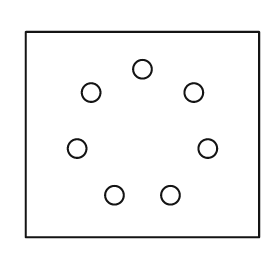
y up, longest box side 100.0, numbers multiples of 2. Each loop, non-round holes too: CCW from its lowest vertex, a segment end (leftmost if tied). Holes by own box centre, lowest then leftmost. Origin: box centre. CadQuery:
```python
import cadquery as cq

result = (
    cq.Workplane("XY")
    .moveTo(-50.0, -44.0)
    .lineTo(50.0, -44.0)
    .lineTo(50.0, 44.0)
    .lineTo(-50.0, 44.0)
    .close()
    .moveTo(-12.0, -26.0)
    .circle(4.0)
    .moveTo(12.0, -26.0)
    .circle(4.0)
    .moveTo(-28.0, -6.0)
    .circle(4.0)
    .moveTo(28.0, -6.0)
    .circle(4.0)
    .moveTo(-22.0, 18.0)
    .circle(4.0)
    .moveTo(22.0, 18.0)
    .circle(4.0)
    .moveTo(0.0, 28.0)
    .circle(4.0)
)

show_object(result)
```